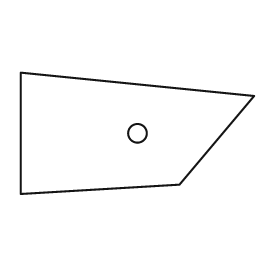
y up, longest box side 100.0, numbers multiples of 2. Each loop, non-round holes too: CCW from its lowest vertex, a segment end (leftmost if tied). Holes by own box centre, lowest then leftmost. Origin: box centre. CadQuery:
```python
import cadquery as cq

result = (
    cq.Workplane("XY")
    .moveTo(-50.0, -26.0)
    .lineTo(18.0, -22.0)
    .lineTo(50.0, 16.0)
    .lineTo(-50.0, 26.0)
    .close()
    .moveTo(0.0, 0.0)
    .circle(4.0)
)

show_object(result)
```